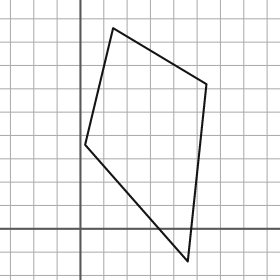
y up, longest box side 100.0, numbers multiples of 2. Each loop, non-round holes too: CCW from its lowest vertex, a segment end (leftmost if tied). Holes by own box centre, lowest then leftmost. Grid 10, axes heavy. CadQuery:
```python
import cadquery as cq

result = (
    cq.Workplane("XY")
    .moveTo(46.0, -14.0)
    .lineTo(54.0, 62.0)
    .lineTo(14.0, 86.0)
    .lineTo(2.0, 36.0)
    .close()
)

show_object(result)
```